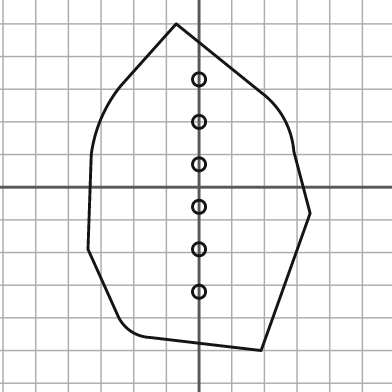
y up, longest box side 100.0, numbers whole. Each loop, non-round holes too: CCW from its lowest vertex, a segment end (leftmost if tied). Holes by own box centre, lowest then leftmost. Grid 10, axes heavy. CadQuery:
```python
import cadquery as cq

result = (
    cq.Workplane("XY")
    .moveTo(19.0, -50.0)
    .lineTo(34.0, -8.0)
    .lineTo(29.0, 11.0)
    .threePointArc((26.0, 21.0), (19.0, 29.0))
    .lineTo(-7.0, 50.0)
    .lineTo(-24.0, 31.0)
    .threePointArc((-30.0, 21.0), (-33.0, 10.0))
    .lineTo(-34.0, -19.0)
    .lineTo(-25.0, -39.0)
    .threePointArc((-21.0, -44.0), (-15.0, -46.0))
    .close()
    .moveTo(0.0, -32.0)
    .circle(2.0)
    .moveTo(0.0, -19.0)
    .circle(2.0)
    .moveTo(0.0, -6.0)
    .circle(2.0)
    .moveTo(0.0, 7.0)
    .circle(2.0)
    .moveTo(0.0, 20.0)
    .circle(2.0)
    .moveTo(0.0, 33.0)
    .circle(2.0)
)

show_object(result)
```